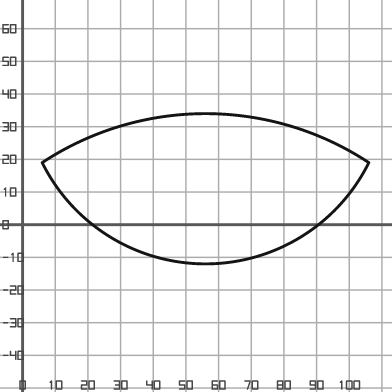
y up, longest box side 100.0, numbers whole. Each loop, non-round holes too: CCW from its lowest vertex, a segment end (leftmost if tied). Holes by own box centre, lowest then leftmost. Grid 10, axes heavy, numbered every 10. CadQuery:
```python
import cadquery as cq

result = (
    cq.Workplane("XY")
    .moveTo(6.0, 19.0)
    .threePointArc((56.0, -12.0), (106.0, 19.0))
    .threePointArc((56.0, 34.0), (6.0, 19.0))
    .close()
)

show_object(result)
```